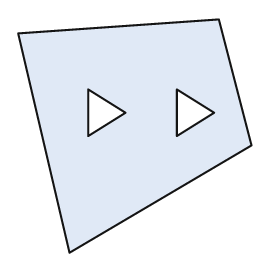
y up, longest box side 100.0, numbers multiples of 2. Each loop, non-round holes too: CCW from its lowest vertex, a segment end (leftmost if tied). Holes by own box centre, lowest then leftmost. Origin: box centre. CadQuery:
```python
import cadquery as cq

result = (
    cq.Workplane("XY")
    .moveTo(-28.0, -50.0)
    .lineTo(50.0, -4.0)
    .lineTo(36.0, 50.0)
    .lineTo(-50.0, 44.0)
    .close()
    .moveTo(-20.0, 0.0)
    .lineTo(-4.0, 10.0)
    .lineTo(-20.0, 20.0)
    .close()
    .moveTo(18.0, 0.0)
    .lineTo(34.0, 10.0)
    .lineTo(18.0, 20.0)
    .close()
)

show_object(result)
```